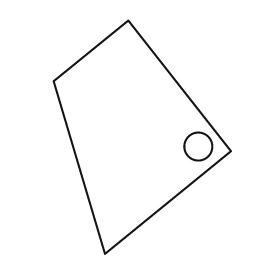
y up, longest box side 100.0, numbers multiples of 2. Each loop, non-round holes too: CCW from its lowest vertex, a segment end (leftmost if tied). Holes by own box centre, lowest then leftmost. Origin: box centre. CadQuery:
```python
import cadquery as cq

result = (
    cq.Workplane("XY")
    .moveTo(-16.0, -50.0)
    .lineTo(38.0, -6.0)
    .lineTo(-6.0, 50.0)
    .lineTo(-38.0, 24.0)
    .close()
    .moveTo(24.0, -4.0)
    .circle(6.0)
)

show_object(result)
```